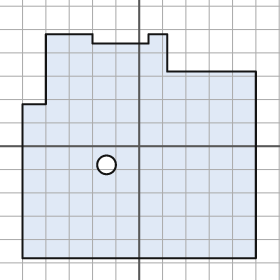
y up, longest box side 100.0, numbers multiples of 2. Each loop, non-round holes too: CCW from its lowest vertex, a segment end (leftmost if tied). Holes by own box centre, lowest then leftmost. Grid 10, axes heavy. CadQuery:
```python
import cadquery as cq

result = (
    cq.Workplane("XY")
    .moveTo(-50.0, -48.0)
    .lineTo(50.0, -48.0)
    .lineTo(50.0, 32.0)
    .lineTo(12.0, 32.0)
    .lineTo(12.0, 48.0)
    .lineTo(4.0, 48.0)
    .lineTo(4.0, 44.0)
    .lineTo(-20.0, 44.0)
    .lineTo(-20.0, 48.0)
    .lineTo(-40.0, 48.0)
    .lineTo(-40.0, 18.0)
    .lineTo(-50.0, 18.0)
    .close()
    .moveTo(-14.0, -8.0)
    .circle(4.0)
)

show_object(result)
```